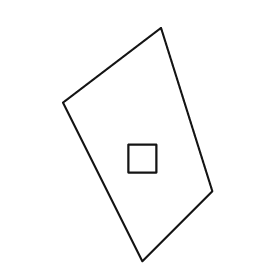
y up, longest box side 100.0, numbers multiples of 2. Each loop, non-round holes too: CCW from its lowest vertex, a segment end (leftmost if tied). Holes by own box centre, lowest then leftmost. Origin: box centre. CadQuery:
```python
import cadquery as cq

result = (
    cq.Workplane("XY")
    .moveTo(2.0, -50.0)
    .lineTo(32.0, -20.0)
    .lineTo(10.0, 50.0)
    .lineTo(-32.0, 18.0)
    .close()
    .moveTo(-4.0, -12.0)
    .lineTo(8.0, -12.0)
    .lineTo(8.0, 0.0)
    .lineTo(-4.0, 0.0)
    .close()
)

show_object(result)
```